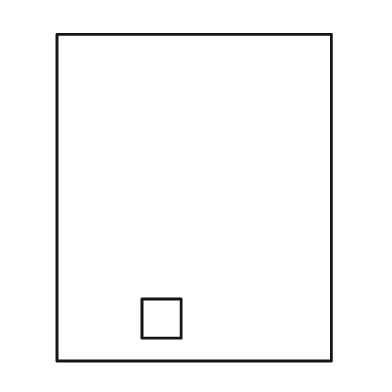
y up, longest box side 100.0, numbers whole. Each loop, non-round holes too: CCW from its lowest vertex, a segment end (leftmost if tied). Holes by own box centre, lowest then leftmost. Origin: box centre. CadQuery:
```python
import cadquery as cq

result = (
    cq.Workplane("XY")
    .moveTo(-42.0, -50.0)
    .lineTo(42.0, -50.0)
    .lineTo(42.0, 50.0)
    .lineTo(-42.0, 50.0)
    .close()
    .moveTo(-16.0, -43.0)
    .lineTo(-4.0, -43.0)
    .lineTo(-4.0, -31.0)
    .lineTo(-16.0, -31.0)
    .close()
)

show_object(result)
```